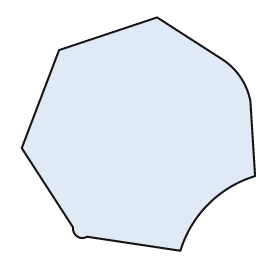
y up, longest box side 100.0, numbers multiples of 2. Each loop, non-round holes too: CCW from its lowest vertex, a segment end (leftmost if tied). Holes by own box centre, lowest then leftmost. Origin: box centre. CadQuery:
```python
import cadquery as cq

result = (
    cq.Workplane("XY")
    .moveTo(18.0, -50.0)
    .threePointArc((30.0, -30.0), (50.0, -18.0))
    .lineTo(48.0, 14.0)
    .threePointArc((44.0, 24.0), (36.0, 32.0))
    .lineTo(8.0, 50.0)
    .lineTo(-34.0, 36.0)
    .lineTo(-50.0, -6.0)
    .lineTo(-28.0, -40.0)
    .threePointArc((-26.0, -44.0), (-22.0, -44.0))
    .close()
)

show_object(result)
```